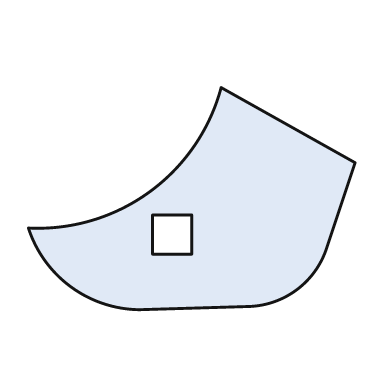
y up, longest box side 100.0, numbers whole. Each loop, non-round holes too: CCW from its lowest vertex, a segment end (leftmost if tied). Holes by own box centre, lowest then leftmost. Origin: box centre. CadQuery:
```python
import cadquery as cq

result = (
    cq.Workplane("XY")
    .moveTo(-16.0, -34.0)
    .lineTo(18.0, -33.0)
    .threePointArc((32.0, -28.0), (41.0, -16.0))
    .lineTo(50.0, 11.0)
    .lineTo(9.0, 34.0)
    .threePointArc((-13.0, 2.0), (-50.0, -9.0))
    .threePointArc((-37.0, -27.0), (-16.0, -34.0))
    .close()
    .moveTo(-12.0, -17.0)
    .lineTo(0.0, -17.0)
    .lineTo(0.0, -5.0)
    .lineTo(-12.0, -5.0)
    .close()
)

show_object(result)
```